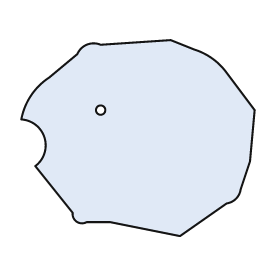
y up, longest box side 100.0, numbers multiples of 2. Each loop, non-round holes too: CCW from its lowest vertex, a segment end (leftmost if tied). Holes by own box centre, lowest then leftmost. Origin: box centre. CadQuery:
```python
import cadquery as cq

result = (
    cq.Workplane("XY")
    .moveTo(18.0, -42.0)
    .lineTo(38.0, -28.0)
    .threePointArc((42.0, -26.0), (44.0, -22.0))
    .lineTo(48.0, -10.0)
    .lineTo(50.0, 12.0)
    .lineTo(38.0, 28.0)
    .threePointArc((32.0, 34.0), (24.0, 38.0))
    .lineTo(14.0, 42.0)
    .lineTo(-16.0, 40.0)
    .threePointArc((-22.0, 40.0), (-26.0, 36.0))
    .lineTo(-38.0, 26.0)
    .threePointArc((-46.0, 18.0), (-50.0, 8.0))
    .threePointArc((-40.0, 0.0), (-44.0, -12.0))
    .lineTo(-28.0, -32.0)
    .threePointArc((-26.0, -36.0), (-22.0, -36.0))
    .lineTo(-12.0, -36.0)
    .close()
    .moveTo(-16.0, 12.0)
    .circle(2.0)
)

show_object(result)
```